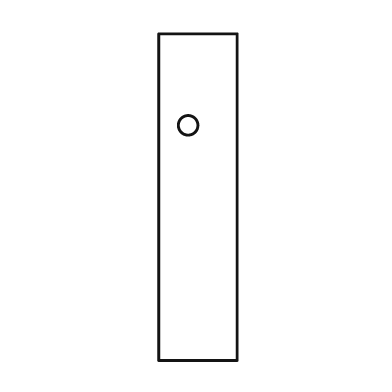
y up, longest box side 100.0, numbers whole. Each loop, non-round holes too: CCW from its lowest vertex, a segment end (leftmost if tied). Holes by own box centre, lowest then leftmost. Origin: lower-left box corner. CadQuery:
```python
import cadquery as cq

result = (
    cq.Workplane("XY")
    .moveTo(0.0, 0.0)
    .lineTo(24.0, 0.0)
    .lineTo(24.0, 100.0)
    .lineTo(0.0, 100.0)
    .close()
    .moveTo(9.0, 72.0)
    .circle(3.0)
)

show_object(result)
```